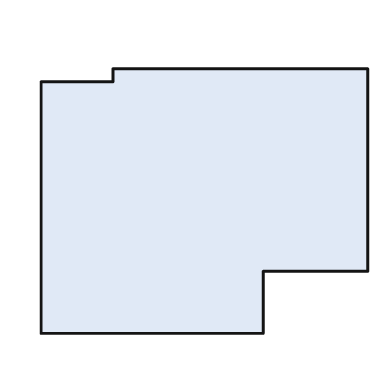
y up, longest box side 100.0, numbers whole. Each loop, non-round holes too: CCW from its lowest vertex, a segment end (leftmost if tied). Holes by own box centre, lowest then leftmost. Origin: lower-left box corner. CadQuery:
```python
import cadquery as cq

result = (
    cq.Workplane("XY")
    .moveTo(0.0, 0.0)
    .lineTo(68.0, 0.0)
    .lineTo(68.0, 19.0)
    .lineTo(100.0, 19.0)
    .lineTo(100.0, 81.0)
    .lineTo(22.0, 81.0)
    .lineTo(22.0, 77.0)
    .lineTo(0.0, 77.0)
    .close()
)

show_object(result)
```